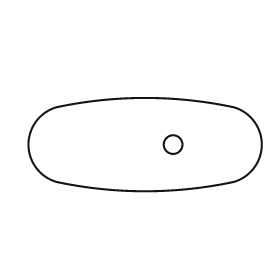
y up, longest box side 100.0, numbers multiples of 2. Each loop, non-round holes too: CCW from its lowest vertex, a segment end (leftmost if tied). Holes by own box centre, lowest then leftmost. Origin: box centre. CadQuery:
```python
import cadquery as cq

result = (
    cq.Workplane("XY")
    .moveTo(-38.0, -16.0)
    .threePointArc((0.0, -20.0), (38.0, -16.0))
    .threePointArc((50.0, 0.0), (38.0, 16.0))
    .threePointArc((0.0, 20.0), (-38.0, 16.0))
    .threePointArc((-50.0, 0.0), (-38.0, -16.0))
    .close()
    .moveTo(12.0, 0.0)
    .circle(4.0)
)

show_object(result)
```